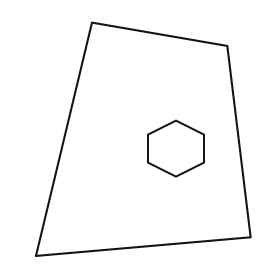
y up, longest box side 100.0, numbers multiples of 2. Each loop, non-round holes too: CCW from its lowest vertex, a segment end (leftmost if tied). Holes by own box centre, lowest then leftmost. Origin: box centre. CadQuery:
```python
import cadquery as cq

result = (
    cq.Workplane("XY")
    .moveTo(-46.0, -50.0)
    .lineTo(46.0, -42.0)
    .lineTo(36.0, 40.0)
    .lineTo(-22.0, 50.0)
    .close()
    .moveTo(14.0, -16.0)
    .lineTo(26.0, -10.0)
    .lineTo(26.0, 2.0)
    .lineTo(14.0, 8.0)
    .lineTo(2.0, 2.0)
    .lineTo(2.0, -10.0)
    .close()
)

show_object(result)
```